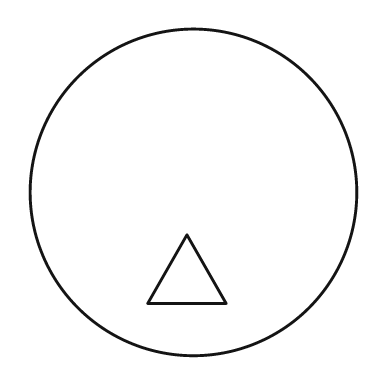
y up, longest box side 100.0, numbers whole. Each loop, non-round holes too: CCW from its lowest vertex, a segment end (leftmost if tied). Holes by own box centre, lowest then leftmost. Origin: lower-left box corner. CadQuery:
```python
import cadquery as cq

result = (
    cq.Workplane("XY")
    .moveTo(50.0, 50.0)
    .circle(50.0)
    .moveTo(36.0, 16.0)
    .lineTo(60.0, 16.0)
    .lineTo(48.0, 37.0)
    .close()
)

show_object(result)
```